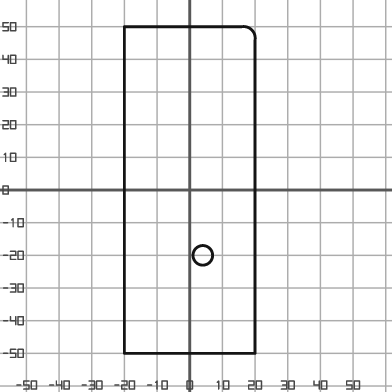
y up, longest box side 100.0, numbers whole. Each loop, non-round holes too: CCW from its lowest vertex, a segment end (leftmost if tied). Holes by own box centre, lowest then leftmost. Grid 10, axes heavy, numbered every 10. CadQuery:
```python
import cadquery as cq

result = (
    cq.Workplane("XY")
    .moveTo(-20.0, -50.0)
    .lineTo(20.0, -50.0)
    .lineTo(20.0, 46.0)
    .threePointArc((19.0, 49.0), (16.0, 50.0))
    .lineTo(-20.0, 50.0)
    .close()
    .moveTo(4.0, -20.0)
    .circle(3.0)
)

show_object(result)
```